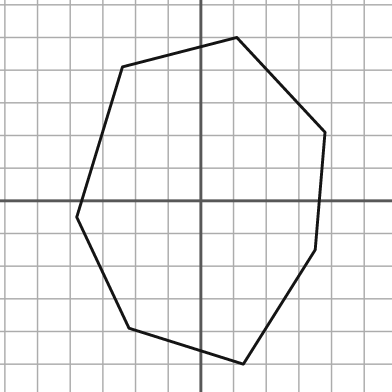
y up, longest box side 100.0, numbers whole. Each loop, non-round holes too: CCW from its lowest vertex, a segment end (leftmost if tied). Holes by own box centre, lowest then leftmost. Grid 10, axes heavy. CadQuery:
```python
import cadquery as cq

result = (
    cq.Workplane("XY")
    .moveTo(13.0, -50.0)
    .lineTo(35.0, -15.0)
    .lineTo(38.0, 21.0)
    .lineTo(11.0, 50.0)
    .lineTo(-24.0, 41.0)
    .lineTo(-38.0, -5.0)
    .lineTo(-22.0, -39.0)
    .close()
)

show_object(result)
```